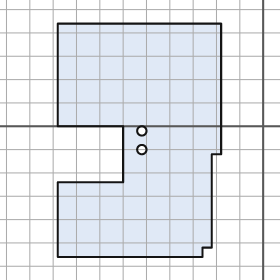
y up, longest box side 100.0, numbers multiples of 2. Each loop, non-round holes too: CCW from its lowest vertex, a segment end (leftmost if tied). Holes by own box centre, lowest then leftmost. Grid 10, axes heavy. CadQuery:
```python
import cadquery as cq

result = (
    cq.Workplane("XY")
    .moveTo(-88.0, -56.0)
    .lineTo(-26.0, -56.0)
    .lineTo(-26.0, -52.0)
    .lineTo(-22.0, -52.0)
    .lineTo(-22.0, -12.0)
    .lineTo(-18.0, -12.0)
    .lineTo(-18.0, 44.0)
    .lineTo(-88.0, 44.0)
    .lineTo(-88.0, 0.0)
    .lineTo(-60.0, 0.0)
    .lineTo(-60.0, -24.0)
    .lineTo(-88.0, -24.0)
    .close()
    .moveTo(-52.0, -10.0)
    .circle(2.0)
    .moveTo(-52.0, -2.0)
    .circle(2.0)
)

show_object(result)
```